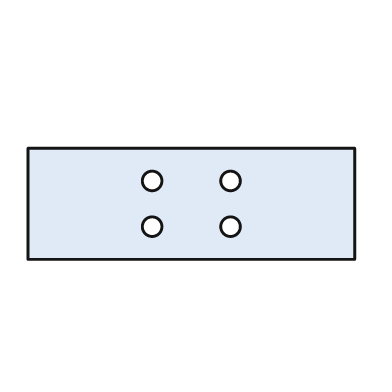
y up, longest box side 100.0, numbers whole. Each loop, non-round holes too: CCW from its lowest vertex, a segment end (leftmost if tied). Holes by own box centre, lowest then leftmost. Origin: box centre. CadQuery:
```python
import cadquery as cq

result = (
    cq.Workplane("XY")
    .moveTo(-50.0, -17.0)
    .lineTo(50.0, -17.0)
    .lineTo(50.0, 17.0)
    .lineTo(-50.0, 17.0)
    .close()
    .moveTo(-12.0, -7.0)
    .circle(3.0)
    .moveTo(12.0, -7.0)
    .circle(3.0)
    .moveTo(-12.0, 7.0)
    .circle(3.0)
    .moveTo(12.0, 7.0)
    .circle(3.0)
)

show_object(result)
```